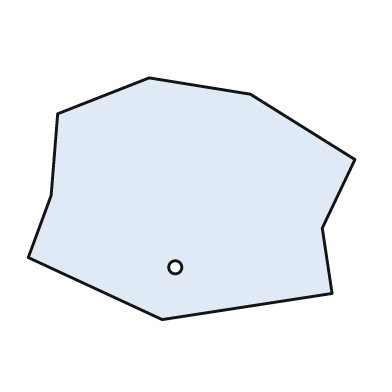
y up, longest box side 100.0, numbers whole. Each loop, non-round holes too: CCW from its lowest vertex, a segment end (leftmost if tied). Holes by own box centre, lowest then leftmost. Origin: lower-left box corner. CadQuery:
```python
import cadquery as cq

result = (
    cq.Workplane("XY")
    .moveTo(41.0, 0.0)
    .lineTo(93.0, 8.0)
    .lineTo(90.0, 28.0)
    .lineTo(100.0, 49.0)
    .lineTo(68.0, 69.0)
    .lineTo(37.0, 74.0)
    .lineTo(9.0, 63.0)
    .lineTo(7.0, 38.0)
    .lineTo(0.0, 19.0)
    .close()
    .moveTo(45.0, 16.0)
    .circle(2.0)
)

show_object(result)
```